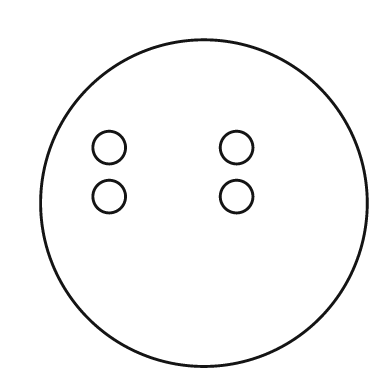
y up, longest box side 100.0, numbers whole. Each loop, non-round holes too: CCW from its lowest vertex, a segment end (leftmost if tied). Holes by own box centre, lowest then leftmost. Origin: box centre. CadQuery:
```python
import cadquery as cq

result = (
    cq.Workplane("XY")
    .moveTo(0.0, 0.0)
    .circle(50.0)
    .moveTo(-29.0, 2.0)
    .circle(5.0)
    .moveTo(10.0, 2.0)
    .circle(5.0)
    .moveTo(-29.0, 17.0)
    .circle(5.0)
    .moveTo(10.0, 17.0)
    .circle(5.0)
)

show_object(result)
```